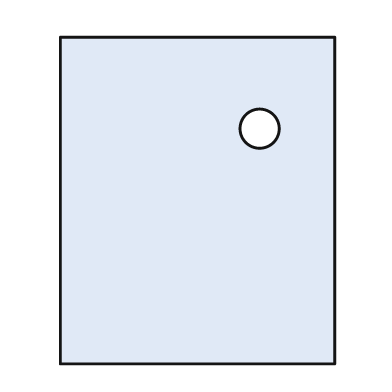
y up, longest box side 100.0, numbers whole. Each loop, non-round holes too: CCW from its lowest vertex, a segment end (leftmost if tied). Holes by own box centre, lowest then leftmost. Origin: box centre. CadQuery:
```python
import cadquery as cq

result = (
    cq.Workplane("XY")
    .moveTo(-42.0, -50.0)
    .lineTo(42.0, -50.0)
    .lineTo(42.0, 50.0)
    .lineTo(-42.0, 50.0)
    .close()
    .moveTo(19.0, 22.0)
    .circle(6.0)
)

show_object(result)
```